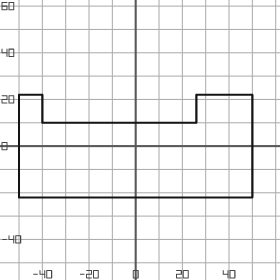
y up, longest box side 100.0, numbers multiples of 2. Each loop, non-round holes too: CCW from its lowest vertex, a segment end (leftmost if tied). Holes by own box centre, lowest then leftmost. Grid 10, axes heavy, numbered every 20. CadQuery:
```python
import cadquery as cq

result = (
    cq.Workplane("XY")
    .moveTo(-50.0, -22.0)
    .lineTo(50.0, -22.0)
    .lineTo(50.0, 22.0)
    .lineTo(26.0, 22.0)
    .lineTo(26.0, 10.0)
    .lineTo(-40.0, 10.0)
    .lineTo(-40.0, 22.0)
    .lineTo(-50.0, 22.0)
    .close()
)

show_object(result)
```